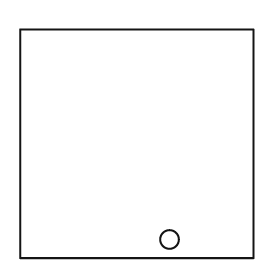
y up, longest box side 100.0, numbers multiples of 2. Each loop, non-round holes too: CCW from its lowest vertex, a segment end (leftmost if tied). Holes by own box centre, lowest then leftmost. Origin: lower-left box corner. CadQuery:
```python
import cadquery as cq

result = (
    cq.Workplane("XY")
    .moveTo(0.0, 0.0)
    .lineTo(100.0, 0.0)
    .lineTo(100.0, 98.0)
    .lineTo(0.0, 98.0)
    .close()
    .moveTo(64.0, 8.0)
    .circle(4.0)
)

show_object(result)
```